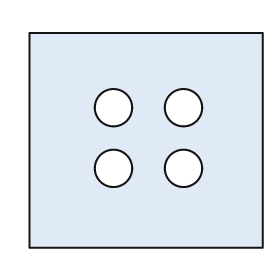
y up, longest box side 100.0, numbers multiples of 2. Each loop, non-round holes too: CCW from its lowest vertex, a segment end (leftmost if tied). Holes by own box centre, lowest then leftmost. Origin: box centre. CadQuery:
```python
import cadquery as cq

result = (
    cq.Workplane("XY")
    .moveTo(-50.0, -46.0)
    .lineTo(50.0, -46.0)
    .lineTo(50.0, 46.0)
    .lineTo(-50.0, 46.0)
    .close()
    .moveTo(-14.0, -12.0)
    .circle(8.0)
    .moveTo(16.0, -12.0)
    .circle(8.0)
    .moveTo(-14.0, 14.0)
    .circle(8.0)
    .moveTo(16.0, 14.0)
    .circle(8.0)
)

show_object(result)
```